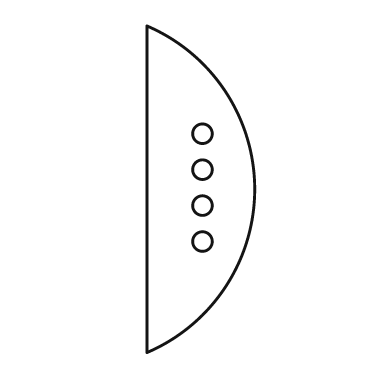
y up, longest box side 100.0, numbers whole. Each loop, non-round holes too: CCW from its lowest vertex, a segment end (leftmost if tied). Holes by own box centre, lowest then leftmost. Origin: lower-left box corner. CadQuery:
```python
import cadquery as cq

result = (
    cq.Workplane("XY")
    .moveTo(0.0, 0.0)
    .threePointArc((33.0, 50.0), (0.0, 100.0))
    .close()
    .moveTo(17.0, 34.0)
    .circle(3.0)
    .moveTo(17.0, 45.0)
    .circle(3.0)
    .moveTo(17.0, 56.0)
    .circle(3.0)
    .moveTo(17.0, 67.0)
    .circle(3.0)
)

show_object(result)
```